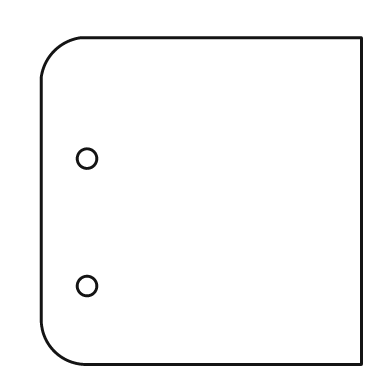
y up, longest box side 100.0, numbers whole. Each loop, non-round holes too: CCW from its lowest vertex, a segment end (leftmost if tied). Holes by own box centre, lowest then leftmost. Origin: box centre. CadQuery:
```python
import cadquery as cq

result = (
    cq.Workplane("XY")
    .moveTo(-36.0, -50.0)
    .lineTo(49.0, -50.0)
    .lineTo(49.0, 50.0)
    .lineTo(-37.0, 50.0)
    .threePointArc((-45.0, 46.0), (-49.0, 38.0))
    .lineTo(-49.0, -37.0)
    .threePointArc((-45.0, -46.0), (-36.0, -50.0))
    .close()
    .moveTo(-35.0, -26.0)
    .circle(3.0)
    .moveTo(-35.0, 13.0)
    .circle(3.0)
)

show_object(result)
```